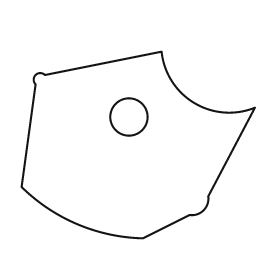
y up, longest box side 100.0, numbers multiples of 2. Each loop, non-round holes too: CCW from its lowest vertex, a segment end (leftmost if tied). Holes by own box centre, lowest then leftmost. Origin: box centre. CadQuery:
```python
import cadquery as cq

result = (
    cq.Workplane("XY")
    .moveTo(2.0, -40.0)
    .lineTo(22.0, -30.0)
    .threePointArc((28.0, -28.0), (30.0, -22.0))
    .lineTo(50.0, 16.0)
    .threePointArc((24.0, 18.0), (10.0, 40.0))
    .lineTo(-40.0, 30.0)
    .threePointArc((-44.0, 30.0), (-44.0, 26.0))
    .lineTo(-50.0, -18.0)
    .threePointArc((-26.0, -34.0), (2.0, -40.0))
    .close()
    .moveTo(-4.0, 12.0)
    .circle(8.0)
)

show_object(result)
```